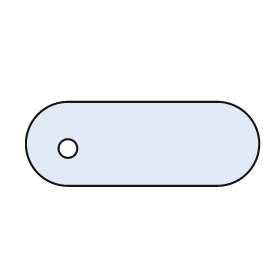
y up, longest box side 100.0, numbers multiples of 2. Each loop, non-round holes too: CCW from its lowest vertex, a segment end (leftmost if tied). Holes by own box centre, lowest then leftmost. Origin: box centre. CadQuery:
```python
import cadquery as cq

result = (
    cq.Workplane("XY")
    .moveTo(-32.0, -18.0)
    .lineTo(32.0, -18.0)
    .threePointArc((50.0, 0.0), (32.0, 18.0))
    .lineTo(-32.0, 18.0)
    .threePointArc((-50.0, 0.0), (-32.0, -18.0))
    .close()
    .moveTo(-32.0, -2.0)
    .circle(4.0)
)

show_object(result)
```